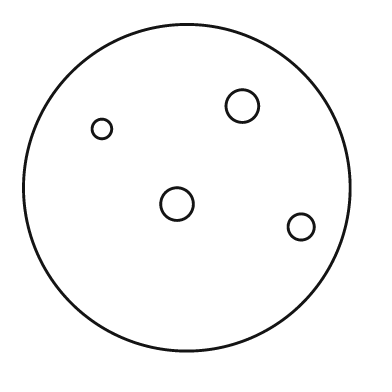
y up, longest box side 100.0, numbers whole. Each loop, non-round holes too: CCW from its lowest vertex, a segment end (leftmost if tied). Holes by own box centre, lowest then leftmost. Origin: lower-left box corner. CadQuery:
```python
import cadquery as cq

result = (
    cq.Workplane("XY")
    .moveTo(50.0, 50.0)
    .circle(50.0)
    .moveTo(85.0, 38.0)
    .circle(4.0)
    .moveTo(47.0, 45.0)
    .circle(5.0)
    .moveTo(24.0, 68.0)
    .circle(3.0)
    .moveTo(67.0, 75.0)
    .circle(5.0)
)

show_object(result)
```